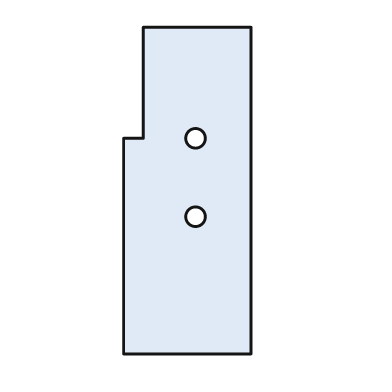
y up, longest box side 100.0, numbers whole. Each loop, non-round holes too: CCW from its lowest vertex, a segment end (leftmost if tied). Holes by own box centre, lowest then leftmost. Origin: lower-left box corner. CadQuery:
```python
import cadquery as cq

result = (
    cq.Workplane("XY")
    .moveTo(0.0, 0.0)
    .lineTo(39.0, 0.0)
    .lineTo(39.0, 100.0)
    .lineTo(6.0, 100.0)
    .lineTo(6.0, 66.0)
    .lineTo(0.0, 66.0)
    .close()
    .moveTo(22.0, 42.0)
    .circle(3.0)
    .moveTo(22.0, 66.0)
    .circle(3.0)
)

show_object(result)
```